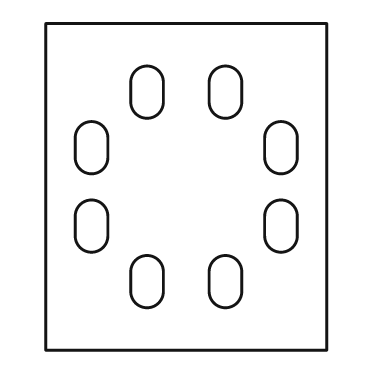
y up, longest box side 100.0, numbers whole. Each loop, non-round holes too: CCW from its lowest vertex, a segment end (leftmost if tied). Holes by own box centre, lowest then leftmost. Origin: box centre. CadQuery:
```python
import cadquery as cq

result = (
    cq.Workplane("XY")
    .moveTo(-43.0, -50.0)
    .lineTo(43.0, -50.0)
    .lineTo(43.0, 50.0)
    .lineTo(-43.0, 50.0)
    .close()
    .moveTo(-17.0, -32.0)
    .threePointArc((-12.0, -37.0), (-7.0, -32.0))
    .lineTo(-7.0, -26.0)
    .threePointArc((-12.0, -21.0), (-17.0, -26.0))
    .close()
    .moveTo(7.0, -32.0)
    .threePointArc((12.0, -37.0), (17.0, -32.0))
    .lineTo(17.0, -26.0)
    .threePointArc((12.0, -21.0), (7.0, -26.0))
    .close()
    .moveTo(-34.0, -15.0)
    .threePointArc((-29.0, -20.0), (-24.0, -15.0))
    .lineTo(-24.0, -9.0)
    .threePointArc((-29.0, -4.0), (-34.0, -9.0))
    .close()
    .moveTo(24.0, -15.0)
    .threePointArc((29.0, -20.0), (34.0, -15.0))
    .lineTo(34.0, -9.0)
    .threePointArc((29.0, -4.0), (24.0, -9.0))
    .close()
    .moveTo(-34.0, 9.0)
    .threePointArc((-29.0, 4.0), (-24.0, 9.0))
    .lineTo(-24.0, 15.0)
    .threePointArc((-29.0, 20.0), (-34.0, 15.0))
    .close()
    .moveTo(24.0, 9.0)
    .threePointArc((29.0, 4.0), (34.0, 9.0))
    .lineTo(34.0, 15.0)
    .threePointArc((29.0, 20.0), (24.0, 15.0))
    .close()
    .moveTo(-17.0, 26.0)
    .threePointArc((-12.0, 21.0), (-7.0, 26.0))
    .lineTo(-7.0, 32.0)
    .threePointArc((-12.0, 37.0), (-17.0, 32.0))
    .close()
    .moveTo(7.0, 26.0)
    .threePointArc((12.0, 21.0), (17.0, 26.0))
    .lineTo(17.0, 32.0)
    .threePointArc((12.0, 37.0), (7.0, 32.0))
    .close()
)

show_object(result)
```